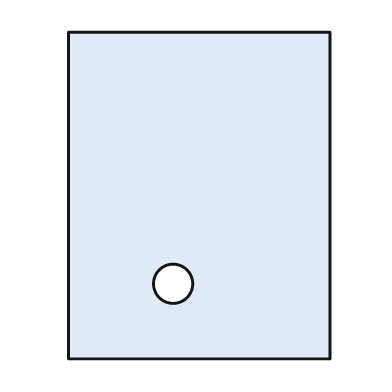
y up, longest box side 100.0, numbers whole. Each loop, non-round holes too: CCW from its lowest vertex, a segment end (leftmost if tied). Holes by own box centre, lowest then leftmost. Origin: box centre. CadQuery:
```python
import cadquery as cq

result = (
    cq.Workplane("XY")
    .moveTo(-40.0, -50.0)
    .lineTo(40.0, -50.0)
    .lineTo(40.0, 50.0)
    .lineTo(-40.0, 50.0)
    .close()
    .moveTo(-8.0, -27.0)
    .circle(6.0)
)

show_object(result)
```